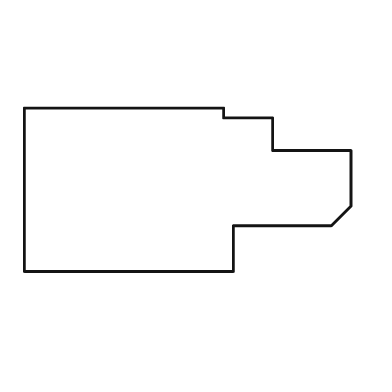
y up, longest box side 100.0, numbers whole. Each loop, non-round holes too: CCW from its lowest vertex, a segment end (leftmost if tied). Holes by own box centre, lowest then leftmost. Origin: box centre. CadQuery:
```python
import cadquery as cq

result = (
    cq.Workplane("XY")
    .moveTo(-50.0, -25.0)
    .lineTo(14.0, -25.0)
    .lineTo(14.0, -11.0)
    .lineTo(44.0, -11.0)
    .lineTo(50.0, -5.0)
    .lineTo(50.0, 12.0)
    .lineTo(26.0, 12.0)
    .lineTo(26.0, 22.0)
    .lineTo(11.0, 22.0)
    .lineTo(11.0, 25.0)
    .lineTo(-50.0, 25.0)
    .close()
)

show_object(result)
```